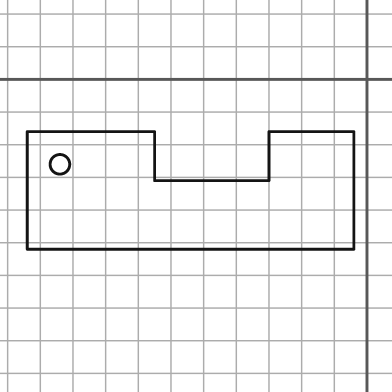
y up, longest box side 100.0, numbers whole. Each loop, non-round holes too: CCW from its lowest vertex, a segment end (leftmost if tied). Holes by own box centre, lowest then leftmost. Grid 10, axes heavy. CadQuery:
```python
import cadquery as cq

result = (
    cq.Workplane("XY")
    .moveTo(-104.0, -52.0)
    .lineTo(-4.0, -52.0)
    .lineTo(-4.0, -16.0)
    .lineTo(-30.0, -16.0)
    .lineTo(-30.0, -31.0)
    .lineTo(-65.0, -31.0)
    .lineTo(-65.0, -16.0)
    .lineTo(-104.0, -16.0)
    .close()
    .moveTo(-94.0, -26.0)
    .circle(3.0)
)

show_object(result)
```